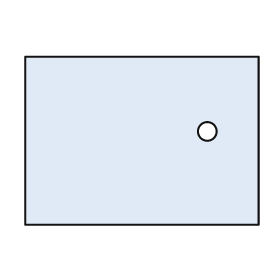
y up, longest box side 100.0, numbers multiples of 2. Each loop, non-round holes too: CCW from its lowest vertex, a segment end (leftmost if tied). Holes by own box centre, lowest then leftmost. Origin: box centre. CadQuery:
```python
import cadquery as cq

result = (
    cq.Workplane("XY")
    .moveTo(-50.0, -36.0)
    .lineTo(50.0, -36.0)
    .lineTo(50.0, 36.0)
    .lineTo(-50.0, 36.0)
    .close()
    .moveTo(28.0, 4.0)
    .circle(4.0)
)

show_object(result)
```